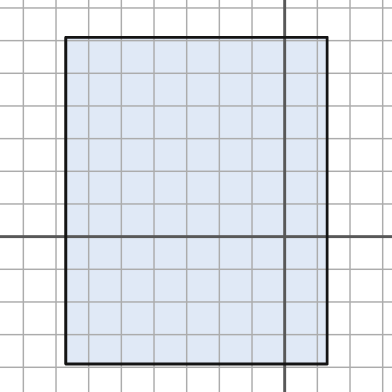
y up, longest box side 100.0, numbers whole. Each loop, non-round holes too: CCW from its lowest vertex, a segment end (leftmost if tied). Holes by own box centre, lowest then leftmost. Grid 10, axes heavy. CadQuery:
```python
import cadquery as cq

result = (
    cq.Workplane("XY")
    .moveTo(-67.0, -39.0)
    .lineTo(13.0, -39.0)
    .lineTo(13.0, 61.0)
    .lineTo(-67.0, 61.0)
    .close()
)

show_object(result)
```